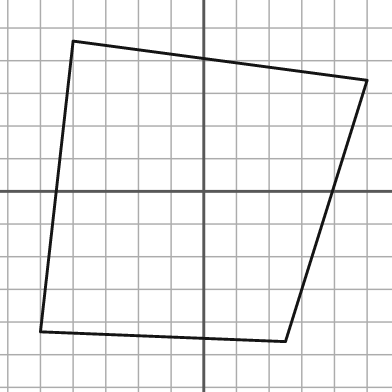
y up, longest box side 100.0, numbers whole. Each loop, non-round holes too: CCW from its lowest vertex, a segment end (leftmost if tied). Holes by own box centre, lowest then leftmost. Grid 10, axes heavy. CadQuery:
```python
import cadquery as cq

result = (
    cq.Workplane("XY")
    .moveTo(25.0, -46.0)
    .lineTo(50.0, 34.0)
    .lineTo(-40.0, 46.0)
    .lineTo(-50.0, -43.0)
    .close()
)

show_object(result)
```